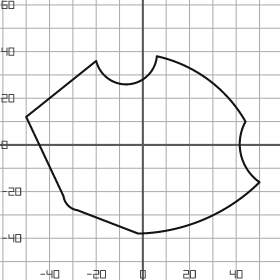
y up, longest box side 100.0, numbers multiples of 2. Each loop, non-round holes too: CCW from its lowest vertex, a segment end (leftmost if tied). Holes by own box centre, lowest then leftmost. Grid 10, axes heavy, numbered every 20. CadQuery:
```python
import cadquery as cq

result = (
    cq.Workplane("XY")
    .moveTo(-2.0, -38.0)
    .threePointArc((26.0, -32.0), (50.0, -16.0))
    .threePointArc((42.0, -4.0), (44.0, 10.0))
    .threePointArc((28.0, 28.0), (6.0, 38.0))
    .threePointArc((-6.0, 26.0), (-20.0, 36.0))
    .lineTo(-50.0, 12.0)
    .lineTo(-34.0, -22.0)
    .threePointArc((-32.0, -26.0), (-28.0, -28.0))
    .close()
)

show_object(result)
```